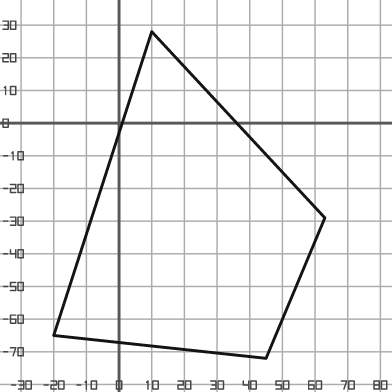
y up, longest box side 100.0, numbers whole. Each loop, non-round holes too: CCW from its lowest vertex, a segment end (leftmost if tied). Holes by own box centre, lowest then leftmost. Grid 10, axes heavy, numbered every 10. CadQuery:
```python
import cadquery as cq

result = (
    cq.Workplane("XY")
    .moveTo(45.0, -72.0)
    .lineTo(63.0, -29.0)
    .lineTo(10.0, 28.0)
    .lineTo(-20.0, -65.0)
    .close()
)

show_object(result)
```